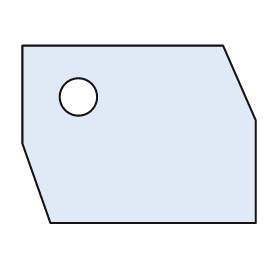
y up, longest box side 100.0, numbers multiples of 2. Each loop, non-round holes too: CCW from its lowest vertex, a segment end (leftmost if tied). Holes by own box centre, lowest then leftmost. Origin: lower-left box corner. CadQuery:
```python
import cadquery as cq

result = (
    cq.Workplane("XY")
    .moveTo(12.0, 0.0)
    .lineTo(100.0, 0.0)
    .lineTo(100.0, 44.0)
    .lineTo(86.0, 76.0)
    .lineTo(0.0, 76.0)
    .lineTo(0.0, 34.0)
    .close()
    .moveTo(24.0, 54.0)
    .circle(8.0)
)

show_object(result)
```